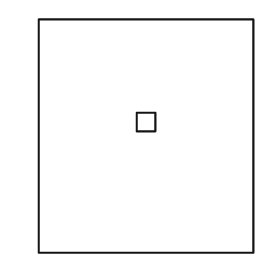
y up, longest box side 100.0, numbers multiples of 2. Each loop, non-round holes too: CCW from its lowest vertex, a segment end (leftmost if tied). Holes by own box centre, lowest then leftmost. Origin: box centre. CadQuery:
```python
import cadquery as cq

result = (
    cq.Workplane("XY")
    .moveTo(-46.0, -50.0)
    .lineTo(46.0, -50.0)
    .lineTo(46.0, 50.0)
    .lineTo(-46.0, 50.0)
    .close()
    .moveTo(-4.0, 2.0)
    .lineTo(4.0, 2.0)
    .lineTo(4.0, 10.0)
    .lineTo(-4.0, 10.0)
    .close()
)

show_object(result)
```